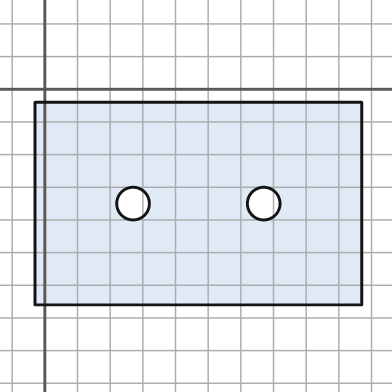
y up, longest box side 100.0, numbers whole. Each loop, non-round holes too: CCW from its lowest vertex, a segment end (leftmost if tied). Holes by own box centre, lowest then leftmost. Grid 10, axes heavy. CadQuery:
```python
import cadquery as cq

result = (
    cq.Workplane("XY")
    .moveTo(-3.0, -66.0)
    .lineTo(97.0, -66.0)
    .lineTo(97.0, -4.0)
    .lineTo(-3.0, -4.0)
    .close()
    .moveTo(27.0, -35.0)
    .circle(5.0)
    .moveTo(67.0, -35.0)
    .circle(5.0)
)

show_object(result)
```